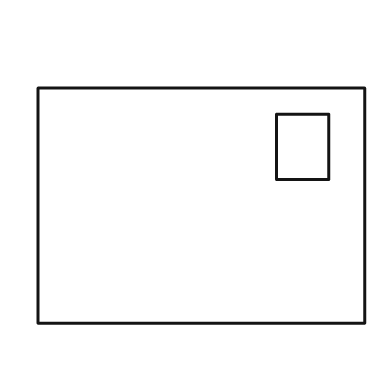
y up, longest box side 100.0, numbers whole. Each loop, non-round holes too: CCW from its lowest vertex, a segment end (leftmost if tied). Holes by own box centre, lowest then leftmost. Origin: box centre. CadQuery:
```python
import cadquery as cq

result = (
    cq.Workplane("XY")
    .moveTo(-50.0, -36.0)
    .lineTo(50.0, -36.0)
    .lineTo(50.0, 36.0)
    .lineTo(-50.0, 36.0)
    .close()
    .moveTo(23.0, 8.0)
    .lineTo(39.0, 8.0)
    .lineTo(39.0, 28.0)
    .lineTo(23.0, 28.0)
    .close()
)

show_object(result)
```